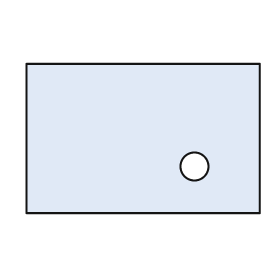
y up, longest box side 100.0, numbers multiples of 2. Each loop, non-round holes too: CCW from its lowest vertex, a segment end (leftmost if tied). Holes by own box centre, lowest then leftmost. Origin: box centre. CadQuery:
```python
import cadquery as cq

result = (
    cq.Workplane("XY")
    .moveTo(-50.0, -32.0)
    .lineTo(50.0, -32.0)
    .lineTo(50.0, 32.0)
    .lineTo(-50.0, 32.0)
    .close()
    .moveTo(22.0, -12.0)
    .circle(6.0)
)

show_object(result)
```